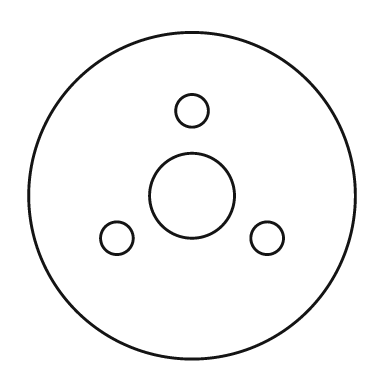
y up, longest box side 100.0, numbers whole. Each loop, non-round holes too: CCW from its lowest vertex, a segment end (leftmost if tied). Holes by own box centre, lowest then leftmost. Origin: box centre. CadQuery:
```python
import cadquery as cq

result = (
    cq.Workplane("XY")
    .moveTo(0.0, 0.0)
    .circle(50.0)
    .moveTo(-23.0, -13.0)
    .circle(5.0)
    .moveTo(23.0, -13.0)
    .circle(5.0)
    .moveTo(0.0, 0.0)
    .circle(13.0)
    .moveTo(0.0, 26.0)
    .circle(5.0)
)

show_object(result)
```